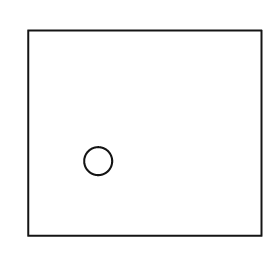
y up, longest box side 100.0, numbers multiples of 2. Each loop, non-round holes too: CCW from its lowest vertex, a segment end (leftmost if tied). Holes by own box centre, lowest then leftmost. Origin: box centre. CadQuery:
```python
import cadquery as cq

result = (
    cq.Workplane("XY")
    .moveTo(-50.0, -44.0)
    .lineTo(50.0, -44.0)
    .lineTo(50.0, 44.0)
    .lineTo(-50.0, 44.0)
    .close()
    .moveTo(-20.0, -12.0)
    .circle(6.0)
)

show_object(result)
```